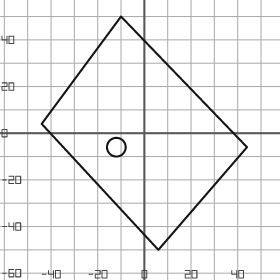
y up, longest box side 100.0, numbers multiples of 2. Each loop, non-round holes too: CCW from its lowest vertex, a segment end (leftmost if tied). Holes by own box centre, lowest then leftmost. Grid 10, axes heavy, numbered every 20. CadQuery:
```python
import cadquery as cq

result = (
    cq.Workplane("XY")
    .moveTo(6.0, -50.0)
    .lineTo(44.0, -6.0)
    .lineTo(-10.0, 50.0)
    .lineTo(-44.0, 4.0)
    .close()
    .moveTo(-12.0, -6.0)
    .circle(4.0)
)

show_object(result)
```